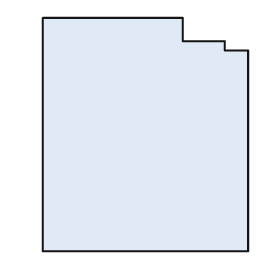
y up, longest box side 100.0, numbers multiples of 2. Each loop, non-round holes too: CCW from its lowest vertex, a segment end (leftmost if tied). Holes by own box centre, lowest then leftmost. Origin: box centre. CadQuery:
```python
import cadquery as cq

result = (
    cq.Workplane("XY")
    .moveTo(-44.0, -50.0)
    .lineTo(44.0, -50.0)
    .lineTo(44.0, 36.0)
    .lineTo(34.0, 36.0)
    .lineTo(34.0, 40.0)
    .lineTo(16.0, 40.0)
    .lineTo(16.0, 50.0)
    .lineTo(-44.0, 50.0)
    .close()
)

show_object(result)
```